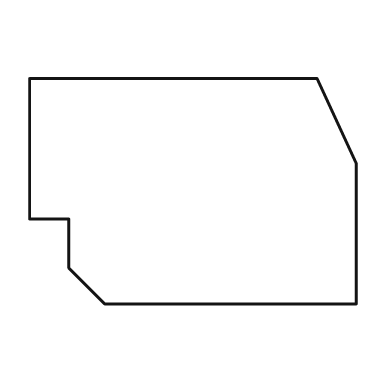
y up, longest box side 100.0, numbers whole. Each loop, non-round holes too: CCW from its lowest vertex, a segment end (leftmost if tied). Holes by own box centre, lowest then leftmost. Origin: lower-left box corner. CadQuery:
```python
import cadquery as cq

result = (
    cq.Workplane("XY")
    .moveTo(23.0, 0.0)
    .lineTo(100.0, 0.0)
    .lineTo(100.0, 43.0)
    .lineTo(88.0, 69.0)
    .lineTo(0.0, 69.0)
    .lineTo(0.0, 26.0)
    .lineTo(12.0, 26.0)
    .lineTo(12.0, 11.0)
    .close()
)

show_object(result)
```